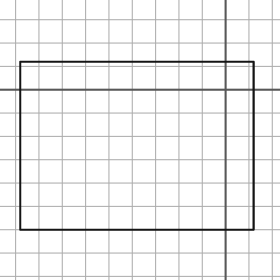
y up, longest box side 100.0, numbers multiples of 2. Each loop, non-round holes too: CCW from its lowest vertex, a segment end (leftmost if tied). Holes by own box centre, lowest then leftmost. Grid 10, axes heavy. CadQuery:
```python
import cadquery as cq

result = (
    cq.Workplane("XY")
    .moveTo(-88.0, -60.0)
    .lineTo(12.0, -60.0)
    .lineTo(12.0, 12.0)
    .lineTo(-88.0, 12.0)
    .close()
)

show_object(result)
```